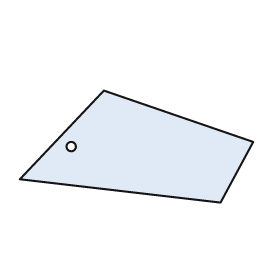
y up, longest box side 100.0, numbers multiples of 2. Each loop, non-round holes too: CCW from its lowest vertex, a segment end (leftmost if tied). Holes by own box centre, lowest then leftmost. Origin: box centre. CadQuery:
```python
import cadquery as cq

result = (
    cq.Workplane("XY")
    .moveTo(36.0, -24.0)
    .lineTo(50.0, 2.0)
    .lineTo(-14.0, 24.0)
    .lineTo(-50.0, -14.0)
    .close()
    .moveTo(-28.0, 0.0)
    .circle(2.0)
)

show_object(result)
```